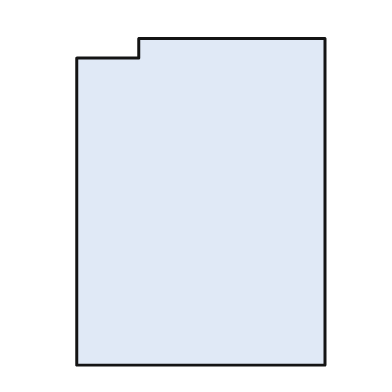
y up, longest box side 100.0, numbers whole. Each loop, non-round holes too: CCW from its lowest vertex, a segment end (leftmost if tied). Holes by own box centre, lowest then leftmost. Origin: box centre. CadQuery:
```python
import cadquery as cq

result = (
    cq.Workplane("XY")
    .moveTo(-38.0, -50.0)
    .lineTo(38.0, -50.0)
    .lineTo(38.0, 50.0)
    .lineTo(-19.0, 50.0)
    .lineTo(-19.0, 44.0)
    .lineTo(-38.0, 44.0)
    .close()
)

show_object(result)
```